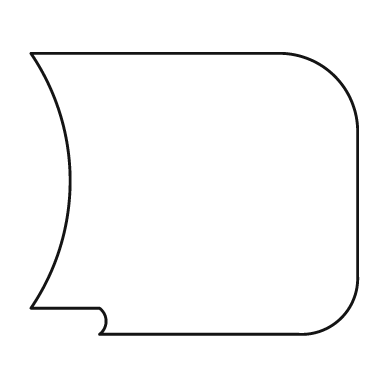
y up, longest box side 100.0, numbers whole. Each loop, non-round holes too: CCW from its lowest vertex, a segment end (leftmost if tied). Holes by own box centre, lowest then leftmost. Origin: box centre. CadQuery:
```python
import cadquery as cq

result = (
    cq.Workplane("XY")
    .moveTo(-29.0, -43.0)
    .lineTo(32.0, -43.0)
    .threePointArc((45.0, -38.0), (50.0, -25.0))
    .lineTo(50.0, 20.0)
    .threePointArc((43.0, 36.0), (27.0, 43.0))
    .lineTo(-50.0, 43.0)
    .threePointArc((-38.0, 4.0), (-50.0, -35.0))
    .lineTo(-29.0, -35.0)
    .threePointArc((-27.0, -39.0), (-29.0, -43.0))
    .close()
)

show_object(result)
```